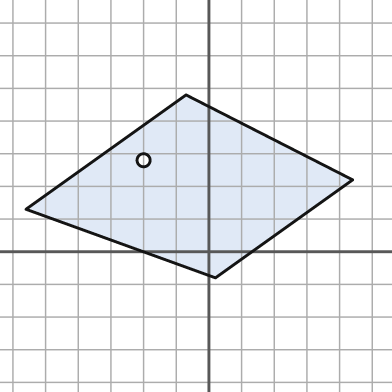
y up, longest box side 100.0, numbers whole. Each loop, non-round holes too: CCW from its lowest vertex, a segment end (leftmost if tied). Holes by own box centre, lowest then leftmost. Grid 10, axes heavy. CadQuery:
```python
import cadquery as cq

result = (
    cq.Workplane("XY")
    .moveTo(2.0, -8.0)
    .lineTo(44.0, 22.0)
    .lineTo(-7.0, 48.0)
    .lineTo(-56.0, 13.0)
    .close()
    .moveTo(-20.0, 28.0)
    .circle(2.0)
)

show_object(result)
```